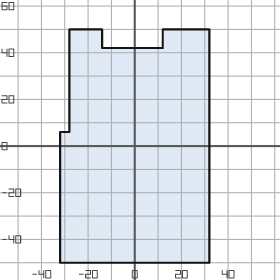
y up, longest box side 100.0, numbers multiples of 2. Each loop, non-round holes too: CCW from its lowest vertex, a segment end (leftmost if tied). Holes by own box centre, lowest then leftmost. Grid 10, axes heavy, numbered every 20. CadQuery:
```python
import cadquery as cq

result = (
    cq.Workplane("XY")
    .moveTo(-32.0, -50.0)
    .lineTo(32.0, -50.0)
    .lineTo(32.0, 50.0)
    .lineTo(12.0, 50.0)
    .lineTo(12.0, 42.0)
    .lineTo(-14.0, 42.0)
    .lineTo(-14.0, 50.0)
    .lineTo(-28.0, 50.0)
    .lineTo(-28.0, 6.0)
    .lineTo(-32.0, 6.0)
    .close()
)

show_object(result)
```